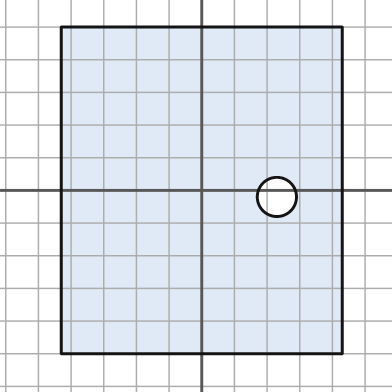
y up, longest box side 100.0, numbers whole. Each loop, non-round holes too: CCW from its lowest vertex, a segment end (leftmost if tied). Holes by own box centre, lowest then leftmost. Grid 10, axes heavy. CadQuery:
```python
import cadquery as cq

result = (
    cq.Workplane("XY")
    .moveTo(-43.0, -50.0)
    .lineTo(43.0, -50.0)
    .lineTo(43.0, 50.0)
    .lineTo(-43.0, 50.0)
    .close()
    .moveTo(23.0, -2.0)
    .circle(6.0)
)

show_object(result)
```